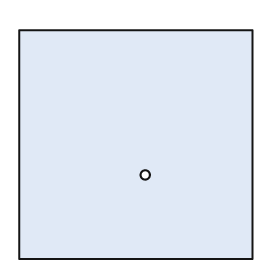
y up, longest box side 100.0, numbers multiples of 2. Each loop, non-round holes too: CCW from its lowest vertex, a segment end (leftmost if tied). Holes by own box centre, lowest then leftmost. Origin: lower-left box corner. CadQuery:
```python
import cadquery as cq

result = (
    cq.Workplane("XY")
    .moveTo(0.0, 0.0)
    .lineTo(100.0, 0.0)
    .lineTo(100.0, 98.0)
    .lineTo(0.0, 98.0)
    .close()
    .moveTo(54.0, 36.0)
    .circle(2.0)
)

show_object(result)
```